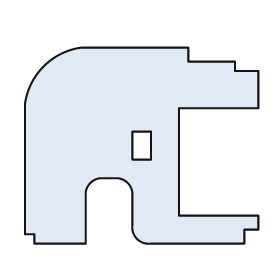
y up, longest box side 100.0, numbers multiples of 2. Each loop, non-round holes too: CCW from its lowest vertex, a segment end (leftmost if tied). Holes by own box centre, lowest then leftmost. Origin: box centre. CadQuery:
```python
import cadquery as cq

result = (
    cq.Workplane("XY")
    .moveTo(-46.0, -42.0)
    .lineTo(-24.0, -42.0)
    .lineTo(-24.0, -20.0)
    .threePointArc((-22.0, -16.0), (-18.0, -14.0))
    .lineTo(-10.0, -14.0)
    .threePointArc((-6.0, -16.0), (-4.0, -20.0))
    .lineTo(-4.0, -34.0)
    .threePointArc((-2.0, -40.0), (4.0, -42.0))
    .lineTo(44.0, -42.0)
    .lineTo(44.0, -36.0)
    .lineTo(50.0, -36.0)
    .lineTo(50.0, -30.0)
    .lineTo(16.0, -30.0)
    .lineTo(16.0, 16.0)
    .lineTo(50.0, 16.0)
    .lineTo(50.0, 32.0)
    .lineTo(40.0, 32.0)
    .lineTo(40.0, 36.0)
    .lineTo(20.0, 36.0)
    .lineTo(20.0, 42.0)
    .lineTo(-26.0, 42.0)
    .threePointArc((-42.0, 34.0), (-50.0, 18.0))
    .lineTo(-50.0, -38.0)
    .lineTo(-46.0, -38.0)
    .close()
    .moveTo(-4.0, -6.0)
    .lineTo(4.0, -6.0)
    .lineTo(4.0, 6.0)
    .lineTo(-4.0, 6.0)
    .close()
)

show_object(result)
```